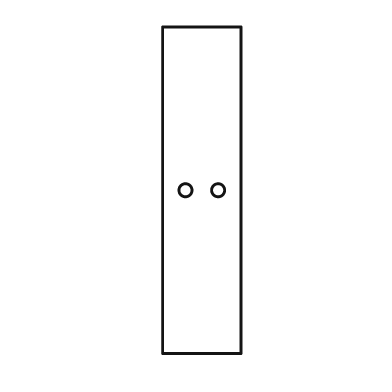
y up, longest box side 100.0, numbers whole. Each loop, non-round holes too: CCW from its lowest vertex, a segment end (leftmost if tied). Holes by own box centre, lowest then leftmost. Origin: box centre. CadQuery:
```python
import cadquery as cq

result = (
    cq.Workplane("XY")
    .moveTo(-12.0, -50.0)
    .lineTo(12.0, -50.0)
    .lineTo(12.0, 50.0)
    .lineTo(-12.0, 50.0)
    .close()
    .moveTo(-5.0, 0.0)
    .circle(2.0)
    .moveTo(5.0, 0.0)
    .circle(2.0)
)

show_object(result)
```